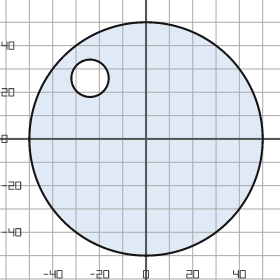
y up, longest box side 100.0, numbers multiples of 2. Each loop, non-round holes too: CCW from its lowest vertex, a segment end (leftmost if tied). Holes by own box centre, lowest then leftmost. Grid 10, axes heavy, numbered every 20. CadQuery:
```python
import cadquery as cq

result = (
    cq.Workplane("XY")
    .moveTo(0.0, 0.0)
    .circle(50.0)
    .moveTo(-24.0, 26.0)
    .circle(8.0)
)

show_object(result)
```